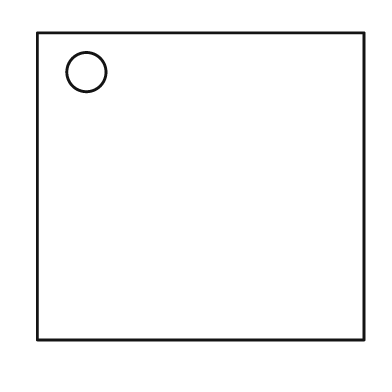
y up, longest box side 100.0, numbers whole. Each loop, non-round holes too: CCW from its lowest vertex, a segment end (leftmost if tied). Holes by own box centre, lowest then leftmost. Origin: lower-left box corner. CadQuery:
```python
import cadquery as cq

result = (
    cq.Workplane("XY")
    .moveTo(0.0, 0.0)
    .lineTo(100.0, 0.0)
    .lineTo(100.0, 94.0)
    .lineTo(0.0, 94.0)
    .close()
    .moveTo(15.0, 82.0)
    .circle(6.0)
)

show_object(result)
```